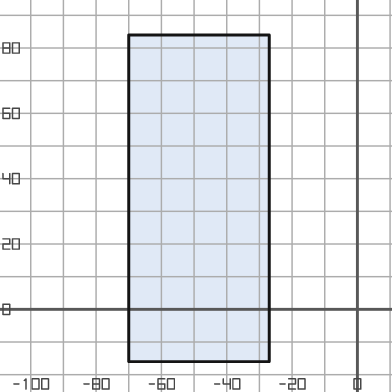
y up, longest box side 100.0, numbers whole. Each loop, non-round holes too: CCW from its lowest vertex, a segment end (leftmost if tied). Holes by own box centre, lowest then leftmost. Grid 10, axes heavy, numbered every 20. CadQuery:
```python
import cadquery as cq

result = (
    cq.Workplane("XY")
    .moveTo(-70.0, -16.0)
    .lineTo(-27.0, -16.0)
    .lineTo(-27.0, 84.0)
    .lineTo(-70.0, 84.0)
    .close()
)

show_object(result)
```